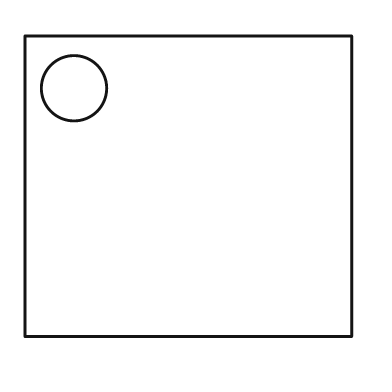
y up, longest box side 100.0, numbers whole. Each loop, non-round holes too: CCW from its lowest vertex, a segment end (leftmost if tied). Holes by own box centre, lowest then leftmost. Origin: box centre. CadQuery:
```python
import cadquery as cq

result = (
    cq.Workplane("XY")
    .moveTo(-50.0, -46.0)
    .lineTo(50.0, -46.0)
    .lineTo(50.0, 46.0)
    .lineTo(-50.0, 46.0)
    .close()
    .moveTo(-35.0, 30.0)
    .circle(10.0)
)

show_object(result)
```